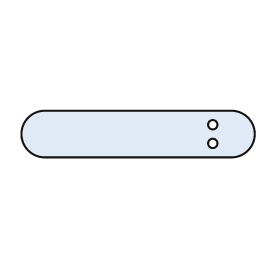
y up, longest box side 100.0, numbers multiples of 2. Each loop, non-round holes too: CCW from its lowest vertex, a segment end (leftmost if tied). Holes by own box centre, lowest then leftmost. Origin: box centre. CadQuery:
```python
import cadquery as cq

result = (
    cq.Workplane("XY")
    .moveTo(-40.0, -10.0)
    .lineTo(40.0, -10.0)
    .threePointArc((50.0, 0.0), (40.0, 10.0))
    .lineTo(-40.0, 10.0)
    .threePointArc((-50.0, 0.0), (-40.0, -10.0))
    .close()
    .moveTo(32.0, -4.0)
    .circle(2.0)
    .moveTo(32.0, 4.0)
    .circle(2.0)
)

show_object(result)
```